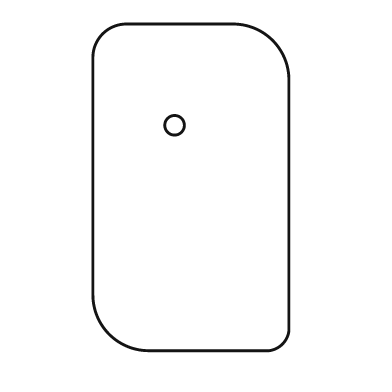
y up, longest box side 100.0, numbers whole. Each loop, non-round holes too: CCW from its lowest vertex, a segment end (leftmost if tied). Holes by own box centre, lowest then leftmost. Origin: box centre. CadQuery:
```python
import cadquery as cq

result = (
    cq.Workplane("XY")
    .moveTo(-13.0, -50.0)
    .lineTo(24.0, -50.0)
    .threePointArc((28.0, -48.0), (30.0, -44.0))
    .lineTo(30.0, 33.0)
    .threePointArc((25.0, 45.0), (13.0, 50.0))
    .lineTo(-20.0, 50.0)
    .threePointArc((-27.0, 47.0), (-30.0, 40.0))
    .lineTo(-30.0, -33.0)
    .threePointArc((-25.0, -45.0), (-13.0, -50.0))
    .close()
    .moveTo(-5.0, 19.0)
    .circle(3.0)
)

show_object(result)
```